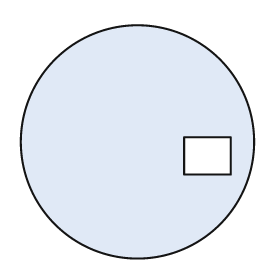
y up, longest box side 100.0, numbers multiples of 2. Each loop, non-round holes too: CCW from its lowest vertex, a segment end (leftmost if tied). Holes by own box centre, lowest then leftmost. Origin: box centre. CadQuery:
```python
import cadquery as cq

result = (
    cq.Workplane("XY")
    .moveTo(0.0, 0.0)
    .circle(50.0)
    .moveTo(20.0, -14.0)
    .lineTo(40.0, -14.0)
    .lineTo(40.0, 2.0)
    .lineTo(20.0, 2.0)
    .close()
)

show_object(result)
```